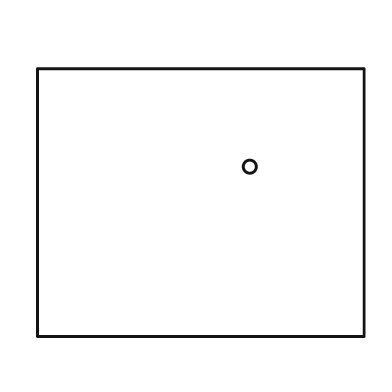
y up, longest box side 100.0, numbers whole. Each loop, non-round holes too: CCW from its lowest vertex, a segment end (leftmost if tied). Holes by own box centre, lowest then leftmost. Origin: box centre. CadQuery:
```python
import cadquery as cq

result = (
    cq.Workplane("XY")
    .moveTo(-50.0, -41.0)
    .lineTo(50.0, -41.0)
    .lineTo(50.0, 41.0)
    .lineTo(-50.0, 41.0)
    .close()
    .moveTo(15.0, 11.0)
    .circle(2.0)
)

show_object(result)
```